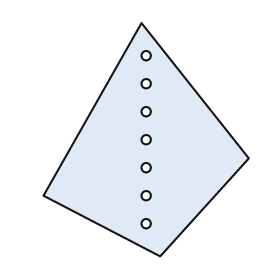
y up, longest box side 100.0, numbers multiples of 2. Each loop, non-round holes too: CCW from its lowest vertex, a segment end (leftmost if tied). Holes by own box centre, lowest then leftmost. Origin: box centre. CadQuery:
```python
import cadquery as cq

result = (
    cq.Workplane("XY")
    .moveTo(6.0, -50.0)
    .lineTo(44.0, -8.0)
    .lineTo(-2.0, 50.0)
    .lineTo(-44.0, -24.0)
    .close()
    .moveTo(0.0, -36.0)
    .circle(2.0)
    .moveTo(0.0, -24.0)
    .circle(2.0)
    .moveTo(0.0, -12.0)
    .circle(2.0)
    .moveTo(0.0, 0.0)
    .circle(2.0)
    .moveTo(0.0, 12.0)
    .circle(2.0)
    .moveTo(0.0, 24.0)
    .circle(2.0)
    .moveTo(0.0, 36.0)
    .circle(2.0)
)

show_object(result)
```